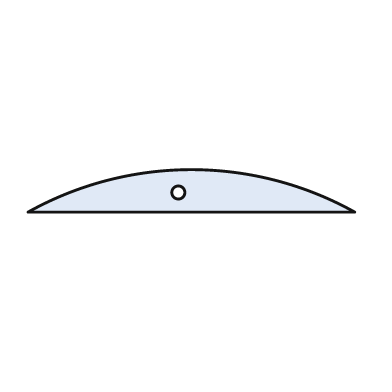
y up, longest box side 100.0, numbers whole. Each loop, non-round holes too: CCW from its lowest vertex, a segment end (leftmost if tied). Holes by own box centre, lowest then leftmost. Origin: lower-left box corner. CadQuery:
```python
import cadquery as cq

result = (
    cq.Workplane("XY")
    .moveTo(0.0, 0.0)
    .lineTo(100.0, 0.0)
    .threePointArc((50.0, 13.0), (0.0, 0.0))
    .close()
    .moveTo(46.0, 6.0)
    .circle(2.0)
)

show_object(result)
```